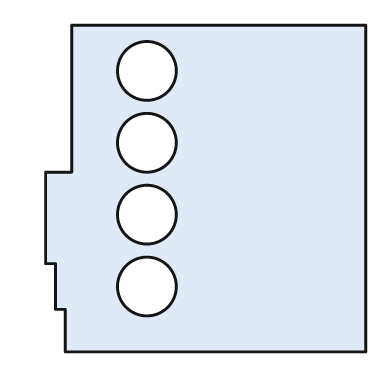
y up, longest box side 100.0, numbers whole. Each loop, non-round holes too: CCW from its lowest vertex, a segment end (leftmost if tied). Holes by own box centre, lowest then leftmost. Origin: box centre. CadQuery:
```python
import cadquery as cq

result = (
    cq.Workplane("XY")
    .moveTo(-43.0, -50.0)
    .lineTo(49.0, -50.0)
    .lineTo(49.0, 50.0)
    .lineTo(-41.0, 50.0)
    .lineTo(-41.0, 5.0)
    .lineTo(-49.0, 5.0)
    .lineTo(-49.0, -23.0)
    .lineTo(-46.0, -23.0)
    .lineTo(-46.0, -37.0)
    .lineTo(-43.0, -37.0)
    .close()
    .moveTo(-18.0, -30.0)
    .circle(9.0)
    .moveTo(-18.0, -8.0)
    .circle(9.0)
    .moveTo(-18.0, 14.0)
    .circle(9.0)
    .moveTo(-18.0, 36.0)
    .circle(9.0)
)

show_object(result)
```